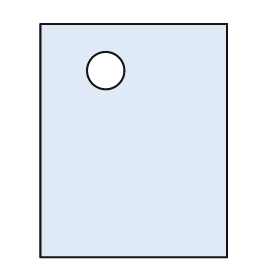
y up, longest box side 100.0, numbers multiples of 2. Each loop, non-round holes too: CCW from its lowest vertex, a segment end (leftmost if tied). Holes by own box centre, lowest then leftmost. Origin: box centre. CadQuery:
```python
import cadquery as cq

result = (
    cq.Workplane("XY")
    .moveTo(-40.0, -50.0)
    .lineTo(40.0, -50.0)
    .lineTo(40.0, 50.0)
    .lineTo(-40.0, 50.0)
    .close()
    .moveTo(-12.0, 30.0)
    .circle(8.0)
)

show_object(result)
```